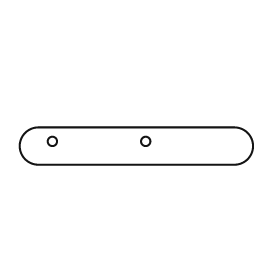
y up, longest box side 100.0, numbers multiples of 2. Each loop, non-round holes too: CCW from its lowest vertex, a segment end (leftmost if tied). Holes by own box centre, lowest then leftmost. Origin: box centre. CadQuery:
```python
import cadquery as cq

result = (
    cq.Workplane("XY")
    .moveTo(-42.0, -8.0)
    .lineTo(42.0, -8.0)
    .threePointArc((50.0, 0.0), (42.0, 8.0))
    .lineTo(-42.0, 8.0)
    .threePointArc((-50.0, 0.0), (-42.0, -8.0))
    .close()
    .moveTo(-36.0, 2.0)
    .circle(2.0)
    .moveTo(4.0, 2.0)
    .circle(2.0)
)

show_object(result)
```